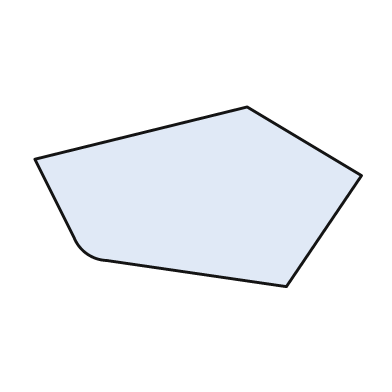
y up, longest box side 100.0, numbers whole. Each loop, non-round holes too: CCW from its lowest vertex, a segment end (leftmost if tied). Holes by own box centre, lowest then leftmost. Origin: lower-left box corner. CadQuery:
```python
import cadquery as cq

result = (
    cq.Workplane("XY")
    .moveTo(77.0, 0.0)
    .lineTo(100.0, 34.0)
    .lineTo(65.0, 55.0)
    .lineTo(0.0, 39.0)
    .lineTo(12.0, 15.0)
    .threePointArc((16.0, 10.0), (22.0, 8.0))
    .close()
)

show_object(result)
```